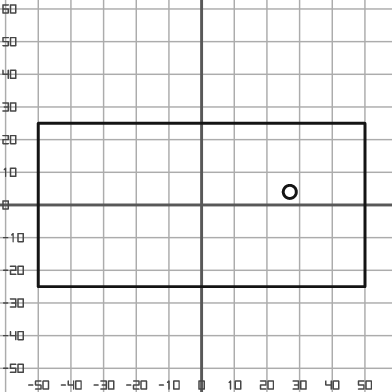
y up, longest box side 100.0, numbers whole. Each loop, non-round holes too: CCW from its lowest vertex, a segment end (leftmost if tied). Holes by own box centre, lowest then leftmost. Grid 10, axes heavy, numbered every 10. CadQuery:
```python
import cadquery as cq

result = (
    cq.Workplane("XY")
    .moveTo(-50.0, -25.0)
    .lineTo(50.0, -25.0)
    .lineTo(50.0, 25.0)
    .lineTo(-50.0, 25.0)
    .close()
    .moveTo(27.0, 4.0)
    .circle(2.0)
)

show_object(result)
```